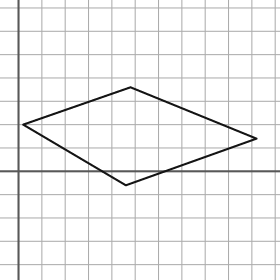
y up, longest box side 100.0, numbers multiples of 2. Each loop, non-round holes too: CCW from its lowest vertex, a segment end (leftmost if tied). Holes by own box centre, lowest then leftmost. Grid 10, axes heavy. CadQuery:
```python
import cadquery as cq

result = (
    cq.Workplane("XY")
    .moveTo(46.0, -6.0)
    .lineTo(102.0, 14.0)
    .lineTo(48.0, 36.0)
    .lineTo(2.0, 20.0)
    .close()
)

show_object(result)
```